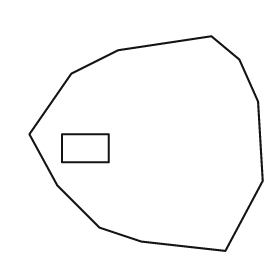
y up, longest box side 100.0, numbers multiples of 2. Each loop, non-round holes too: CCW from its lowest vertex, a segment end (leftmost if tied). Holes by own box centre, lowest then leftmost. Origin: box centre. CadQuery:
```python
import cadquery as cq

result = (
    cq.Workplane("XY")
    .moveTo(34.0, -46.0)
    .lineTo(50.0, -16.0)
    .lineTo(48.0, 18.0)
    .lineTo(40.0, 36.0)
    .lineTo(28.0, 46.0)
    .lineTo(-12.0, 40.0)
    .lineTo(-32.0, 30.0)
    .lineTo(-50.0, 4.0)
    .lineTo(-38.0, -18.0)
    .lineTo(-20.0, -36.0)
    .lineTo(-2.0, -42.0)
    .close()
    .moveTo(-36.0, -8.0)
    .lineTo(-16.0, -8.0)
    .lineTo(-16.0, 4.0)
    .lineTo(-36.0, 4.0)
    .close()
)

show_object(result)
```